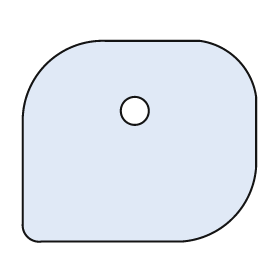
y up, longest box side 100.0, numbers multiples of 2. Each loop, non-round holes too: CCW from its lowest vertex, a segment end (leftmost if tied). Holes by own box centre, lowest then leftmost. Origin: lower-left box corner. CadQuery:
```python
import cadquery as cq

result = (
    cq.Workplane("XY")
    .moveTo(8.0, 0.0)
    .lineTo(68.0, 0.0)
    .threePointArc((90.0, 10.0), (100.0, 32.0))
    .lineTo(100.0, 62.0)
    .threePointArc((92.0, 78.0), (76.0, 86.0))
    .lineTo(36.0, 86.0)
    .threePointArc((10.0, 76.0), (0.0, 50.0))
    .lineTo(0.0, 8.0)
    .threePointArc((2.0, 2.0), (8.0, 0.0))
    .close()
    .moveTo(48.0, 56.0)
    .circle(6.0)
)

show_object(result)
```